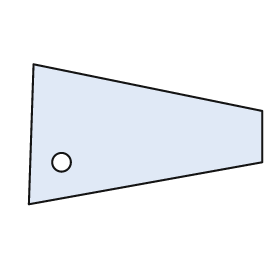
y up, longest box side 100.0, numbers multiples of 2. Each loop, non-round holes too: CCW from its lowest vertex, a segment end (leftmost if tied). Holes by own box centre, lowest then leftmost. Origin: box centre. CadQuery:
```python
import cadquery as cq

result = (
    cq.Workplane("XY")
    .moveTo(-50.0, -30.0)
    .lineTo(50.0, -12.0)
    .lineTo(50.0, 10.0)
    .lineTo(-48.0, 30.0)
    .close()
    .moveTo(-36.0, -12.0)
    .circle(4.0)
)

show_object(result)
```